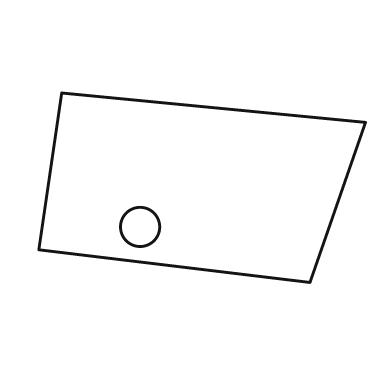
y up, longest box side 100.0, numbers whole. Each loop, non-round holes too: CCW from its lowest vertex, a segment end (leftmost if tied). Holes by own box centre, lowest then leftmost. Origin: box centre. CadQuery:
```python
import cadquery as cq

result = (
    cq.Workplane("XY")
    .moveTo(33.0, -29.0)
    .lineTo(50.0, 20.0)
    .lineTo(-43.0, 29.0)
    .lineTo(-50.0, -19.0)
    .close()
    .moveTo(-19.0, -12.0)
    .circle(6.0)
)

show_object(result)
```